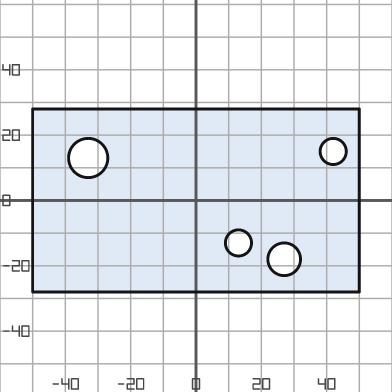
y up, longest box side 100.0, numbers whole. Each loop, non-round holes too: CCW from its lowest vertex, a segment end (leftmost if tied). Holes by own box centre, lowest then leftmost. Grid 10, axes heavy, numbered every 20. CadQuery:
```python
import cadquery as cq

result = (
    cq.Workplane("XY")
    .moveTo(-50.0, -28.0)
    .lineTo(50.0, -28.0)
    .lineTo(50.0, 28.0)
    .lineTo(-50.0, 28.0)
    .close()
    .moveTo(27.0, -18.0)
    .circle(5.0)
    .moveTo(13.0, -13.0)
    .circle(4.0)
    .moveTo(-33.0, 13.0)
    .circle(6.0)
    .moveTo(42.0, 15.0)
    .circle(4.0)
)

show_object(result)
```